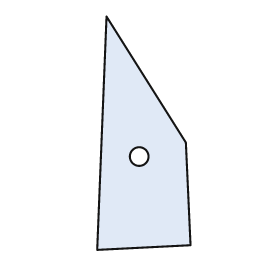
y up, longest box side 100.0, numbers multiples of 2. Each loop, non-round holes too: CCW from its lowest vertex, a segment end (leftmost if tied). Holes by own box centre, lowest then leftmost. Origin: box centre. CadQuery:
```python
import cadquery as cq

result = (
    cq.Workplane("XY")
    .moveTo(-20.0, -50.0)
    .lineTo(20.0, -48.0)
    .lineTo(18.0, -4.0)
    .lineTo(-16.0, 50.0)
    .close()
    .moveTo(-2.0, -10.0)
    .circle(4.0)
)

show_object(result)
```